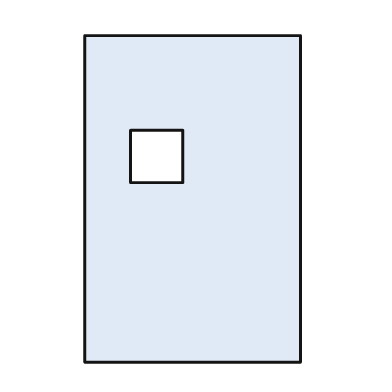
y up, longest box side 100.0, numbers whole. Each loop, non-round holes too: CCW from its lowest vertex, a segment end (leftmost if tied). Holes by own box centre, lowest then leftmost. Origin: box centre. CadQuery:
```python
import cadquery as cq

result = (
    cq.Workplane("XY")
    .moveTo(-33.0, -50.0)
    .lineTo(33.0, -50.0)
    .lineTo(33.0, 50.0)
    .lineTo(-33.0, 50.0)
    .close()
    .moveTo(-19.0, 5.0)
    .lineTo(-3.0, 5.0)
    .lineTo(-3.0, 21.0)
    .lineTo(-19.0, 21.0)
    .close()
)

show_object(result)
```